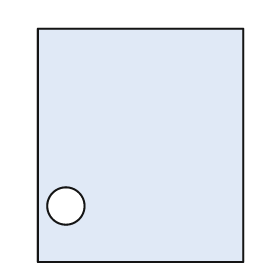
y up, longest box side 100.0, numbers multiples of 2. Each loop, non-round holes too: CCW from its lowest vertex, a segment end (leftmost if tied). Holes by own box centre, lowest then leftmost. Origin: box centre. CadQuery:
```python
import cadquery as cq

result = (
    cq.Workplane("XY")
    .moveTo(-44.0, -50.0)
    .lineTo(44.0, -50.0)
    .lineTo(44.0, 50.0)
    .lineTo(-44.0, 50.0)
    .close()
    .moveTo(-32.0, -26.0)
    .circle(8.0)
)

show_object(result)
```